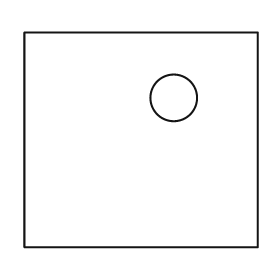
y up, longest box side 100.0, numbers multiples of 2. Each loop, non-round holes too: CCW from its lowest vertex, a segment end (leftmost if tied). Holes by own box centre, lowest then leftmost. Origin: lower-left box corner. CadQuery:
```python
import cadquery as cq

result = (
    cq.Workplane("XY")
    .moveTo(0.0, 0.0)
    .lineTo(100.0, 0.0)
    .lineTo(100.0, 92.0)
    .lineTo(0.0, 92.0)
    .close()
    .moveTo(64.0, 64.0)
    .circle(10.0)
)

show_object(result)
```